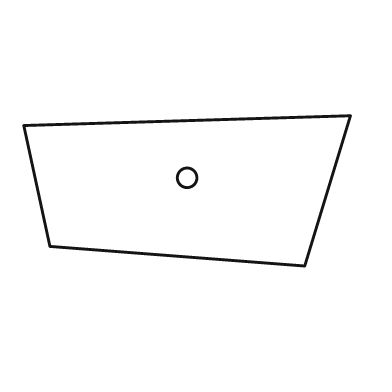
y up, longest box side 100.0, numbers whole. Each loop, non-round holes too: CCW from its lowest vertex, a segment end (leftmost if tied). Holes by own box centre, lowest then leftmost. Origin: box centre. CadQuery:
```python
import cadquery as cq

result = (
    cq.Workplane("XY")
    .moveTo(36.0, -23.0)
    .lineTo(50.0, 23.0)
    .lineTo(-50.0, 20.0)
    .lineTo(-42.0, -17.0)
    .close()
    .moveTo(0.0, 4.0)
    .circle(3.0)
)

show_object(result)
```